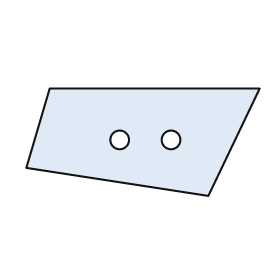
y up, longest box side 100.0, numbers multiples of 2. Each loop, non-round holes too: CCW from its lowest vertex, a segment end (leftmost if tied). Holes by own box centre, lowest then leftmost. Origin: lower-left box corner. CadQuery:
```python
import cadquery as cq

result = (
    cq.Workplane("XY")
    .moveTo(78.0, 0.0)
    .lineTo(100.0, 46.0)
    .lineTo(10.0, 46.0)
    .lineTo(0.0, 12.0)
    .close()
    .moveTo(40.0, 24.0)
    .circle(4.0)
    .moveTo(62.0, 24.0)
    .circle(4.0)
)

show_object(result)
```